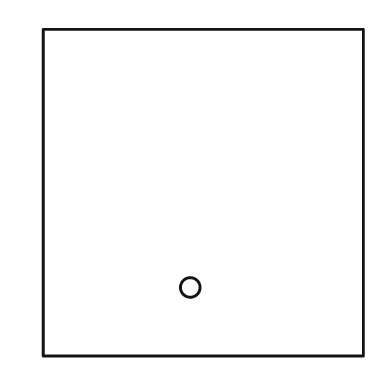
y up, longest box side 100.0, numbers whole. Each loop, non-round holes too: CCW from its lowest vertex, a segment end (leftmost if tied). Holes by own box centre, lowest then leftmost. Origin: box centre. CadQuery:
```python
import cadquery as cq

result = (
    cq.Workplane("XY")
    .moveTo(-49.0, -50.0)
    .lineTo(49.0, -50.0)
    .lineTo(49.0, 50.0)
    .lineTo(-49.0, 50.0)
    .close()
    .moveTo(-4.0, -29.0)
    .circle(3.0)
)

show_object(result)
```